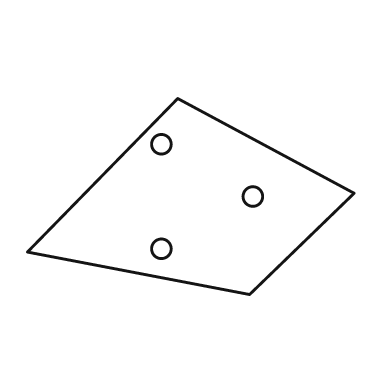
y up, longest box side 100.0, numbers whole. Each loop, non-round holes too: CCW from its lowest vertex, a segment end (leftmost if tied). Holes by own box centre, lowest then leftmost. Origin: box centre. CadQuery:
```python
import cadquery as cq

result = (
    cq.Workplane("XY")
    .moveTo(18.0, -30.0)
    .lineTo(50.0, 1.0)
    .lineTo(-4.0, 30.0)
    .lineTo(-50.0, -17.0)
    .close()
    .moveTo(-9.0, -16.0)
    .circle(3.0)
    .moveTo(19.0, 0.0)
    .circle(3.0)
    .moveTo(-9.0, 16.0)
    .circle(3.0)
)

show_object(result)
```